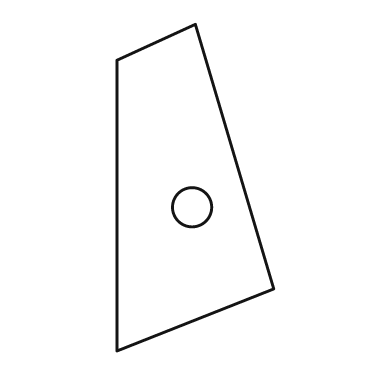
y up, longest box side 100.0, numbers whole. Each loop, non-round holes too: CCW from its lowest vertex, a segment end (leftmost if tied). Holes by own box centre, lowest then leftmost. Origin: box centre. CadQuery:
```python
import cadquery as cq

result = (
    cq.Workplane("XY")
    .moveTo(-24.0, -50.0)
    .lineTo(24.0, -31.0)
    .lineTo(0.0, 50.0)
    .lineTo(-24.0, 39.0)
    .close()
    .moveTo(-1.0, -6.0)
    .circle(6.0)
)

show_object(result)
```